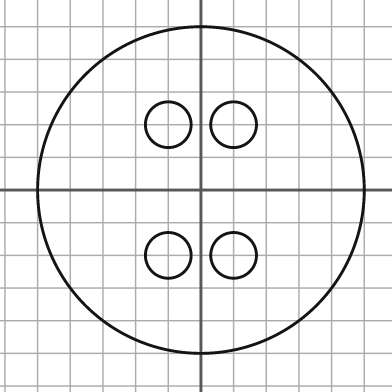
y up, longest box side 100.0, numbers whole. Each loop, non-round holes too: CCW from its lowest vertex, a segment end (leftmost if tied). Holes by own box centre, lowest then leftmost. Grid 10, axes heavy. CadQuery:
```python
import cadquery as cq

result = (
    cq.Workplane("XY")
    .moveTo(0.0, 0.0)
    .circle(50.0)
    .moveTo(-10.0, -20.0)
    .circle(7.0)
    .moveTo(10.0, -20.0)
    .circle(7.0)
    .moveTo(-10.0, 20.0)
    .circle(7.0)
    .moveTo(10.0, 20.0)
    .circle(7.0)
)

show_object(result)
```